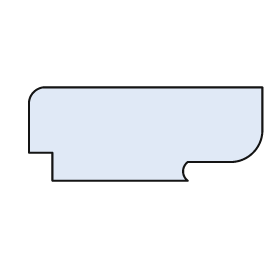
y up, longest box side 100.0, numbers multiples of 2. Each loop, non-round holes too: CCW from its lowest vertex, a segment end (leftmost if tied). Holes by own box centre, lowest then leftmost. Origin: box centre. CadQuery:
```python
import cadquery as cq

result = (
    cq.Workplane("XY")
    .moveTo(-40.0, -20.0)
    .lineTo(18.0, -20.0)
    .threePointArc((16.0, -16.0), (18.0, -12.0))
    .lineTo(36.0, -12.0)
    .threePointArc((46.0, -8.0), (50.0, 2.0))
    .lineTo(50.0, 20.0)
    .lineTo(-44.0, 20.0)
    .threePointArc((-48.0, 18.0), (-50.0, 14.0))
    .lineTo(-50.0, -8.0)
    .lineTo(-40.0, -8.0)
    .close()
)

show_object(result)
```